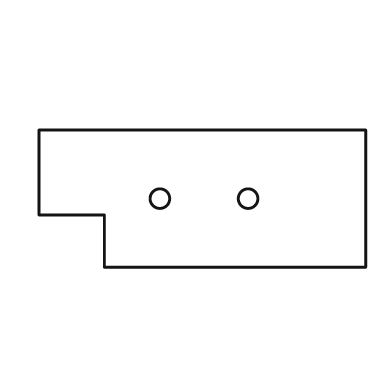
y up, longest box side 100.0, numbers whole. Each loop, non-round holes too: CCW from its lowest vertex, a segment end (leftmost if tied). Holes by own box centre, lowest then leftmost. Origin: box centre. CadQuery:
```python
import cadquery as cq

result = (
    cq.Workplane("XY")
    .moveTo(-30.0, -21.0)
    .lineTo(50.0, -21.0)
    .lineTo(50.0, 21.0)
    .lineTo(-50.0, 21.0)
    .lineTo(-50.0, -5.0)
    .lineTo(-30.0, -5.0)
    .close()
    .moveTo(-13.0, 0.0)
    .circle(3.0)
    .moveTo(14.0, 0.0)
    .circle(3.0)
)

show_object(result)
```